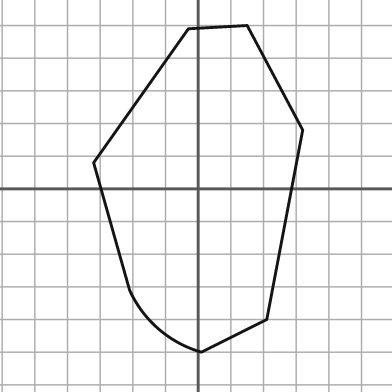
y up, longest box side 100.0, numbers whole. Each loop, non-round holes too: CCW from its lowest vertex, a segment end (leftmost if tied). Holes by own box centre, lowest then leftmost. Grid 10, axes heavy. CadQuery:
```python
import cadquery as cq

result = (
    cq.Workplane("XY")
    .moveTo(1.0, -50.0)
    .lineTo(21.0, -40.0)
    .lineTo(32.0, 18.0)
    .lineTo(15.0, 50.0)
    .lineTo(-3.0, 49.0)
    .lineTo(-32.0, 8.0)
    .lineTo(-21.0, -31.0)
    .threePointArc((-12.0, -43.0), (1.0, -50.0))
    .close()
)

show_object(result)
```